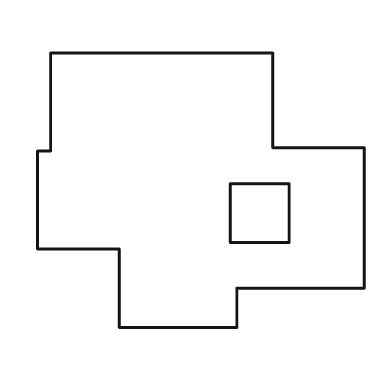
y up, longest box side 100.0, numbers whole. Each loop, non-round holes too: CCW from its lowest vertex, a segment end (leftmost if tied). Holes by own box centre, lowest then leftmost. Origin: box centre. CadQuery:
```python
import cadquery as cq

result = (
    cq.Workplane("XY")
    .moveTo(-25.0, -42.0)
    .lineTo(11.0, -42.0)
    .lineTo(11.0, -30.0)
    .lineTo(50.0, -30.0)
    .lineTo(50.0, 13.0)
    .lineTo(22.0, 13.0)
    .lineTo(22.0, 42.0)
    .lineTo(-46.0, 42.0)
    .lineTo(-46.0, 12.0)
    .lineTo(-50.0, 12.0)
    .lineTo(-50.0, -18.0)
    .lineTo(-25.0, -18.0)
    .close()
    .moveTo(9.0, -16.0)
    .lineTo(27.0, -16.0)
    .lineTo(27.0, 2.0)
    .lineTo(9.0, 2.0)
    .close()
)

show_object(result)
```